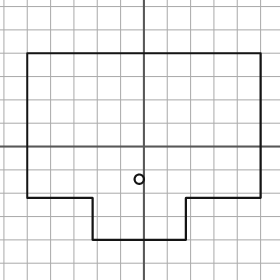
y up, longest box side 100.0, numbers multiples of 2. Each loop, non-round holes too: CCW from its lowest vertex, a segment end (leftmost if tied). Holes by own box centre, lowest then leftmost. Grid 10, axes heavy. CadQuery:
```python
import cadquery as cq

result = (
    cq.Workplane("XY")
    .moveTo(-22.0, -40.0)
    .lineTo(18.0, -40.0)
    .lineTo(18.0, -22.0)
    .lineTo(50.0, -22.0)
    .lineTo(50.0, 40.0)
    .lineTo(-50.0, 40.0)
    .lineTo(-50.0, -22.0)
    .lineTo(-22.0, -22.0)
    .close()
    .moveTo(-2.0, -14.0)
    .circle(2.0)
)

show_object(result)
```